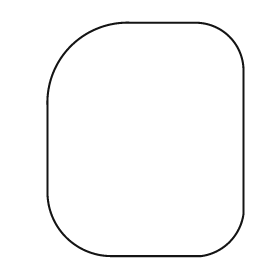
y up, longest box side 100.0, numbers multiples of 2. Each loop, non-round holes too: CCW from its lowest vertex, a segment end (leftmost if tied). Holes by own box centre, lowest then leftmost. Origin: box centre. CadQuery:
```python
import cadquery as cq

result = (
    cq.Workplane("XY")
    .moveTo(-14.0, -50.0)
    .lineTo(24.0, -50.0)
    .threePointArc((36.0, -44.0), (42.0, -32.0))
    .lineTo(42.0, 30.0)
    .threePointArc((36.0, 44.0), (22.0, 50.0))
    .lineTo(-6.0, 50.0)
    .threePointArc((-32.0, 40.0), (-42.0, 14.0))
    .lineTo(-42.0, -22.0)
    .threePointArc((-34.0, -42.0), (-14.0, -50.0))
    .close()
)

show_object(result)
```